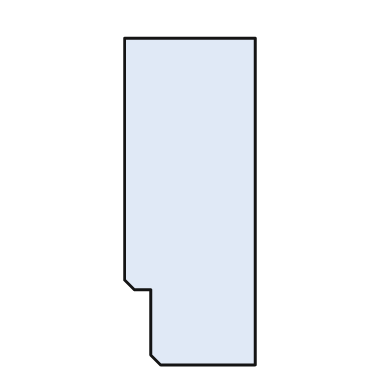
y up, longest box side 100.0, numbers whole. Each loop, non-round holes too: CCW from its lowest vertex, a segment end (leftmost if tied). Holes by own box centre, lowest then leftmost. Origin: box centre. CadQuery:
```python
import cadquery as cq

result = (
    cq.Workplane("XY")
    .moveTo(-9.0, -50.0)
    .lineTo(20.0, -50.0)
    .lineTo(20.0, 50.0)
    .lineTo(-20.0, 50.0)
    .lineTo(-20.0, -24.0)
    .lineTo(-17.0, -27.0)
    .lineTo(-12.0, -27.0)
    .lineTo(-12.0, -47.0)
    .close()
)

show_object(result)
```